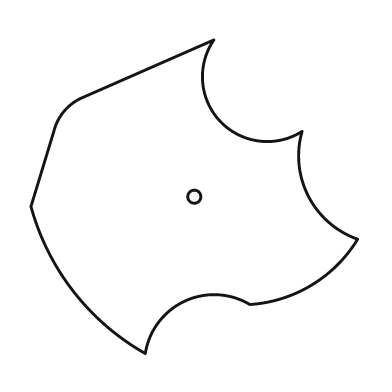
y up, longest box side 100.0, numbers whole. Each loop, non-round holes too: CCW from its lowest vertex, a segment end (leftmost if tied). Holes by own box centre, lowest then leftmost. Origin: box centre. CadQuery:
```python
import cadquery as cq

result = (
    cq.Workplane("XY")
    .moveTo(-15.0, -48.0)
    .threePointArc((-3.0, -32.0), (17.0, -33.0))
    .threePointArc((36.0, -27.0), (50.0, -13.0))
    .threePointArc((35.0, 0.0), (33.0, 20.0))
    .threePointArc((8.0, 23.0), (6.0, 48.0))
    .lineTo(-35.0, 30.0)
    .threePointArc((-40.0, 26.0), (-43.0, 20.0))
    .lineTo(-50.0, -3.0)
    .threePointArc((-37.0, -29.0), (-15.0, -48.0))
    .close()
    .moveTo(0.0, 0.0)
    .circle(2.0)
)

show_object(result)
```